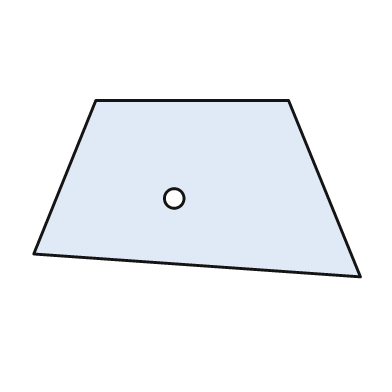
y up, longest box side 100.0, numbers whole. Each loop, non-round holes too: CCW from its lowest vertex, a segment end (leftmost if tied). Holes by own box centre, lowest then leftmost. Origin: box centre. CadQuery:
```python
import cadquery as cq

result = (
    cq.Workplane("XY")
    .moveTo(50.0, -27.0)
    .lineTo(28.0, 27.0)
    .lineTo(-31.0, 27.0)
    .lineTo(-50.0, -20.0)
    .close()
    .moveTo(-7.0, -3.0)
    .circle(3.0)
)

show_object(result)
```